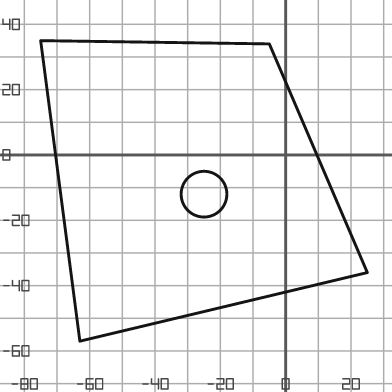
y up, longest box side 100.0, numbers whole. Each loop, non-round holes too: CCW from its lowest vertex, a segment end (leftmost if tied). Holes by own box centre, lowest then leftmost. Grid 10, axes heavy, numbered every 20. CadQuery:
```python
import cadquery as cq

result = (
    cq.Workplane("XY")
    .moveTo(-63.0, -57.0)
    .lineTo(25.0, -36.0)
    .lineTo(-5.0, 34.0)
    .lineTo(-75.0, 35.0)
    .close()
    .moveTo(-25.0, -12.0)
    .circle(7.0)
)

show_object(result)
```